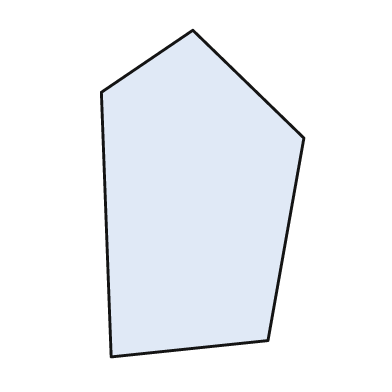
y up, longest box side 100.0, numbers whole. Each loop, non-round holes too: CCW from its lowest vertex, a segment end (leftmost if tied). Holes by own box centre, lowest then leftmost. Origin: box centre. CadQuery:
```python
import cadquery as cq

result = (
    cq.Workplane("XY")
    .moveTo(-28.0, -50.0)
    .lineTo(20.0, -45.0)
    .lineTo(31.0, 17.0)
    .lineTo(-3.0, 50.0)
    .lineTo(-31.0, 31.0)
    .close()
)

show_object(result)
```